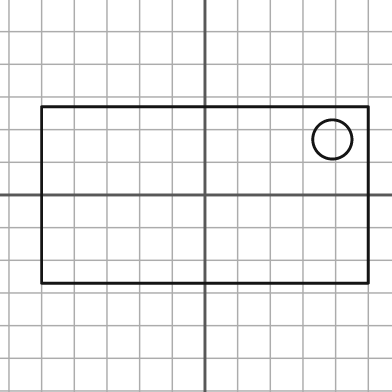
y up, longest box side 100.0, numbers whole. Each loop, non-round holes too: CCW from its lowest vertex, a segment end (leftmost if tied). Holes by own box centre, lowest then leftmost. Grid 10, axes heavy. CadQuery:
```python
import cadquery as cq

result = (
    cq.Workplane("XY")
    .moveTo(-50.0, -27.0)
    .lineTo(50.0, -27.0)
    .lineTo(50.0, 27.0)
    .lineTo(-50.0, 27.0)
    .close()
    .moveTo(39.0, 17.0)
    .circle(6.0)
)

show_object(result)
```